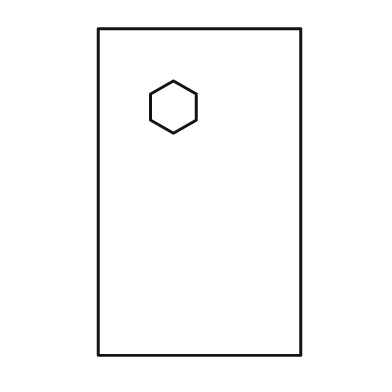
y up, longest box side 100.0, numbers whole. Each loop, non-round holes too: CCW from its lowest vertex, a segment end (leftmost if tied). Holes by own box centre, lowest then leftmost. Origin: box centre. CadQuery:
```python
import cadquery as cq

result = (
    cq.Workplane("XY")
    .moveTo(-31.0, -50.0)
    .lineTo(31.0, -50.0)
    .lineTo(31.0, 50.0)
    .lineTo(-31.0, 50.0)
    .close()
    .moveTo(-8.0, 18.0)
    .lineTo(-1.0, 22.0)
    .lineTo(-1.0, 30.0)
    .lineTo(-8.0, 34.0)
    .lineTo(-15.0, 30.0)
    .lineTo(-15.0, 22.0)
    .close()
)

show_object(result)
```